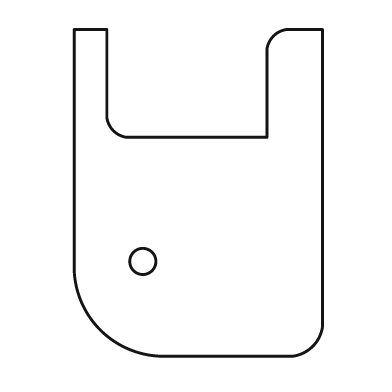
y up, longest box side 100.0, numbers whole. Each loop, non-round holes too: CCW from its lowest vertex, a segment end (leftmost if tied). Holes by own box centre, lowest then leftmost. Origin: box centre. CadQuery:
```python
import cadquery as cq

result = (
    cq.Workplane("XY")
    .moveTo(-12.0, -50.0)
    .lineTo(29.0, -50.0)
    .threePointArc((35.0, -47.0), (38.0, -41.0))
    .lineTo(38.0, 50.0)
    .lineTo(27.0, 50.0)
    .threePointArc((23.0, 48.0), (21.0, 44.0))
    .lineTo(21.0, 17.0)
    .lineTo(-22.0, 17.0)
    .threePointArc((-26.0, 19.0), (-28.0, 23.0))
    .lineTo(-28.0, 50.0)
    .lineTo(-38.0, 50.0)
    .lineTo(-38.0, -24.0)
    .threePointArc((-30.0, -42.0), (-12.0, -50.0))
    .close()
    .moveTo(-17.0, -21.0)
    .circle(4.0)
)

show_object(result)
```